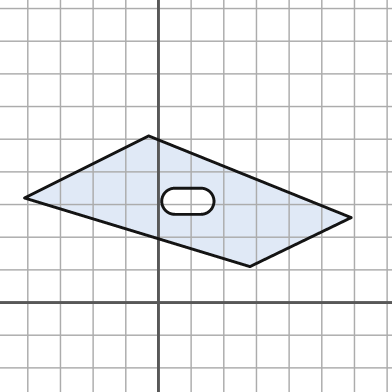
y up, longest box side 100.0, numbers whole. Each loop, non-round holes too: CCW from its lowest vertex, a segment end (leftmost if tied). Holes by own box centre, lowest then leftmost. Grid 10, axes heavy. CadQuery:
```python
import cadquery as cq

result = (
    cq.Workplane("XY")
    .moveTo(28.0, 11.0)
    .lineTo(59.0, 26.0)
    .lineTo(-3.0, 51.0)
    .lineTo(-41.0, 32.0)
    .close()
    .moveTo(5.0, 27.0)
    .lineTo(13.0, 27.0)
    .threePointArc((17.0, 31.0), (13.0, 35.0))
    .lineTo(5.0, 35.0)
    .threePointArc((1.0, 31.0), (5.0, 27.0))
    .close()
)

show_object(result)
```